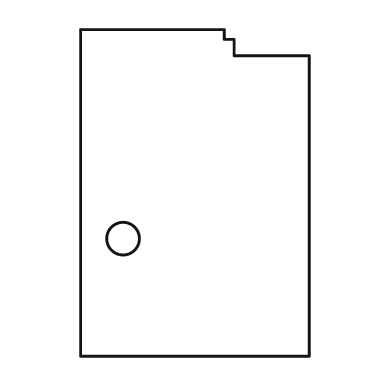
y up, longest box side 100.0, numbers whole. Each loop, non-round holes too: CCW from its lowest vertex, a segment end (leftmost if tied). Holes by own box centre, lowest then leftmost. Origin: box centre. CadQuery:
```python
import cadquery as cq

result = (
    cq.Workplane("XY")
    .moveTo(-35.0, -50.0)
    .lineTo(35.0, -50.0)
    .lineTo(35.0, 42.0)
    .lineTo(12.0, 42.0)
    .lineTo(12.0, 47.0)
    .lineTo(9.0, 47.0)
    .lineTo(9.0, 50.0)
    .lineTo(-35.0, 50.0)
    .close()
    .moveTo(-22.0, -14.0)
    .circle(5.0)
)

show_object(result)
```